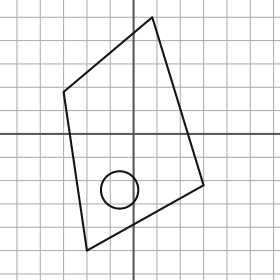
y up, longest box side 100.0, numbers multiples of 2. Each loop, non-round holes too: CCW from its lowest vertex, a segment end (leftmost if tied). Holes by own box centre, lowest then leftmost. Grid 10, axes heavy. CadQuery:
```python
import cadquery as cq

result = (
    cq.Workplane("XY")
    .moveTo(-20.0, -50.0)
    .lineTo(30.0, -22.0)
    .lineTo(8.0, 50.0)
    .lineTo(-30.0, 18.0)
    .close()
    .moveTo(-6.0, -24.0)
    .circle(8.0)
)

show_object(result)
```